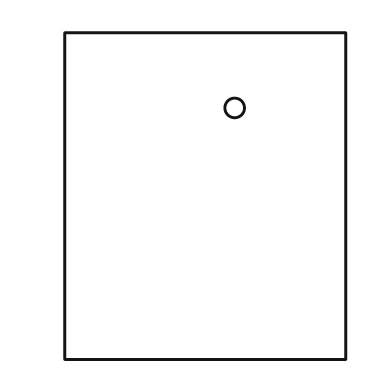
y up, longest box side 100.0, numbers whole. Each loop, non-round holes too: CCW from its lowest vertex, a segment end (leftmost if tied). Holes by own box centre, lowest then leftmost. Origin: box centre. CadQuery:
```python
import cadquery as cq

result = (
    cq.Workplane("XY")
    .moveTo(-43.0, -50.0)
    .lineTo(43.0, -50.0)
    .lineTo(43.0, 50.0)
    .lineTo(-43.0, 50.0)
    .close()
    .moveTo(9.0, 27.0)
    .circle(3.0)
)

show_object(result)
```